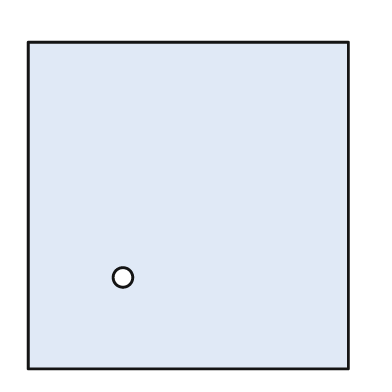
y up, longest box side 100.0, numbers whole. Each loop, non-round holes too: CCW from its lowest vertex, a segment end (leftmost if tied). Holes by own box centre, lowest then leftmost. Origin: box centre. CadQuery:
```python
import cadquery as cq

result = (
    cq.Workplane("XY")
    .moveTo(-49.0, -50.0)
    .lineTo(49.0, -50.0)
    .lineTo(49.0, 50.0)
    .lineTo(-49.0, 50.0)
    .close()
    .moveTo(-20.0, -22.0)
    .circle(3.0)
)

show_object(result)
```